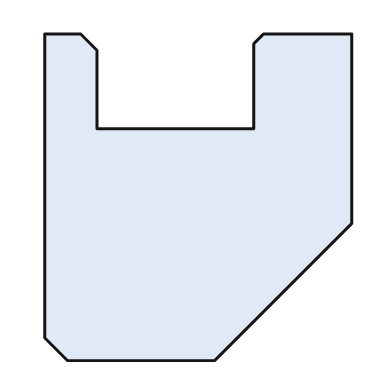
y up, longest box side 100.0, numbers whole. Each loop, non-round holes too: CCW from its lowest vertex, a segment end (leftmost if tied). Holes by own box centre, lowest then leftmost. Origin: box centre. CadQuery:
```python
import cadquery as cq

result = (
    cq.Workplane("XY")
    .moveTo(-40.0, -50.0)
    .lineTo(5.0, -50.0)
    .lineTo(47.0, -8.0)
    .lineTo(47.0, 50.0)
    .lineTo(20.0, 50.0)
    .lineTo(17.0, 47.0)
    .lineTo(17.0, 21.0)
    .lineTo(-31.0, 21.0)
    .lineTo(-31.0, 45.0)
    .lineTo(-36.0, 50.0)
    .lineTo(-47.0, 50.0)
    .lineTo(-47.0, -43.0)
    .close()
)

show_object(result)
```